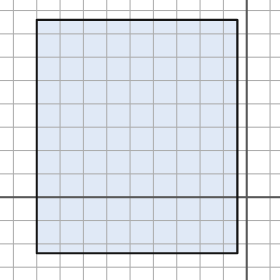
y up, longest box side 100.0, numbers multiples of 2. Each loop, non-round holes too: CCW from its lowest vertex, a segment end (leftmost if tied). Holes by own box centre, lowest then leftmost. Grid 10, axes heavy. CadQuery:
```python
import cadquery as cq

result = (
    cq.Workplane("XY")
    .moveTo(-90.0, -24.0)
    .lineTo(-4.0, -24.0)
    .lineTo(-4.0, 76.0)
    .lineTo(-90.0, 76.0)
    .close()
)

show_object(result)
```